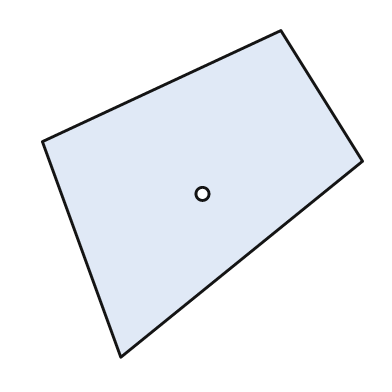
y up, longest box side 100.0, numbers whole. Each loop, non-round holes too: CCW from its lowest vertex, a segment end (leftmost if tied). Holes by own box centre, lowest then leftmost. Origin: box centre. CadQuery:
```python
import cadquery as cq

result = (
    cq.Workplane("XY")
    .moveTo(-25.0, -50.0)
    .lineTo(49.0, 10.0)
    .lineTo(24.0, 50.0)
    .lineTo(-49.0, 16.0)
    .close()
    .moveTo(0.0, 0.0)
    .circle(2.0)
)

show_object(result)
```